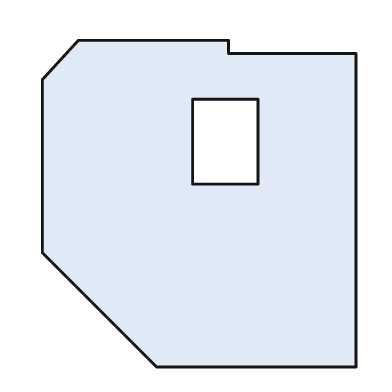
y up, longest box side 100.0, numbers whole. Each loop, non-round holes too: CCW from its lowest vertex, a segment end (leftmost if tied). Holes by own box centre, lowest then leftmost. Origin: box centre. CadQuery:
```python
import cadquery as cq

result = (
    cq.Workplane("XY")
    .moveTo(-13.0, -50.0)
    .lineTo(48.0, -50.0)
    .lineTo(48.0, 46.0)
    .lineTo(9.0, 46.0)
    .lineTo(9.0, 50.0)
    .lineTo(-37.0, 50.0)
    .lineTo(-48.0, 38.0)
    .lineTo(-48.0, -15.0)
    .close()
    .moveTo(-2.0, 6.0)
    .lineTo(18.0, 6.0)
    .lineTo(18.0, 32.0)
    .lineTo(-2.0, 32.0)
    .close()
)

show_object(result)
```